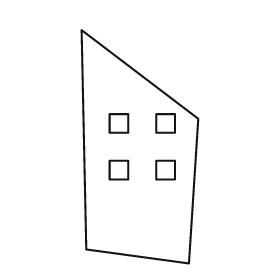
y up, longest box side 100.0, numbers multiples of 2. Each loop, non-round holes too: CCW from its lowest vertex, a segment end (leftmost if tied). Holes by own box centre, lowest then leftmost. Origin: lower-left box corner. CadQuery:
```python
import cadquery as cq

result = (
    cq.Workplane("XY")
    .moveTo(46.0, 0.0)
    .lineTo(50.0, 62.0)
    .lineTo(0.0, 100.0)
    .lineTo(2.0, 6.0)
    .close()
    .moveTo(12.0, 36.0)
    .lineTo(20.0, 36.0)
    .lineTo(20.0, 44.0)
    .lineTo(12.0, 44.0)
    .close()
    .moveTo(32.0, 36.0)
    .lineTo(40.0, 36.0)
    .lineTo(40.0, 44.0)
    .lineTo(32.0, 44.0)
    .close()
    .moveTo(12.0, 56.0)
    .lineTo(20.0, 56.0)
    .lineTo(20.0, 64.0)
    .lineTo(12.0, 64.0)
    .close()
    .moveTo(32.0, 56.0)
    .lineTo(40.0, 56.0)
    .lineTo(40.0, 64.0)
    .lineTo(32.0, 64.0)
    .close()
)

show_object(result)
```